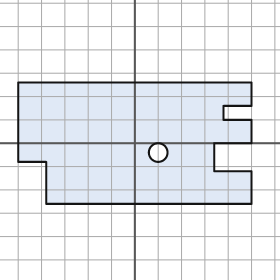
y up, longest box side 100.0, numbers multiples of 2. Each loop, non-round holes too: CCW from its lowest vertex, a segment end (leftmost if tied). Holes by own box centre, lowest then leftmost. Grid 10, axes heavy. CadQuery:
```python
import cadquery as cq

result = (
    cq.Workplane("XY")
    .moveTo(-38.0, -26.0)
    .lineTo(50.0, -26.0)
    .lineTo(50.0, -12.0)
    .lineTo(34.0, -12.0)
    .lineTo(34.0, 0.0)
    .lineTo(50.0, 0.0)
    .lineTo(50.0, 10.0)
    .lineTo(38.0, 10.0)
    .lineTo(38.0, 16.0)
    .lineTo(50.0, 16.0)
    .lineTo(50.0, 26.0)
    .lineTo(-50.0, 26.0)
    .lineTo(-50.0, -8.0)
    .lineTo(-38.0, -8.0)
    .close()
    .moveTo(10.0, -4.0)
    .circle(4.0)
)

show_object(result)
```